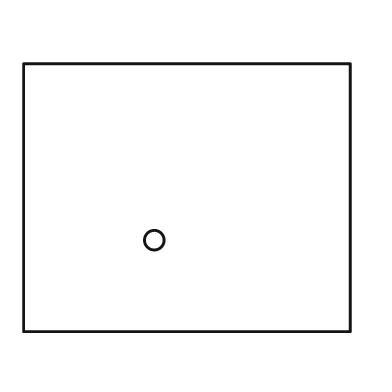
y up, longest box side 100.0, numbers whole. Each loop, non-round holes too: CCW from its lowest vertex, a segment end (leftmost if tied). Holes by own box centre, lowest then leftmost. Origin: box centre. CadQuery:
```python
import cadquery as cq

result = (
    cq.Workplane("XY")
    .moveTo(-50.0, -41.0)
    .lineTo(50.0, -41.0)
    .lineTo(50.0, 41.0)
    .lineTo(-50.0, 41.0)
    .close()
    .moveTo(-10.0, -13.0)
    .circle(3.0)
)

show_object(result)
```